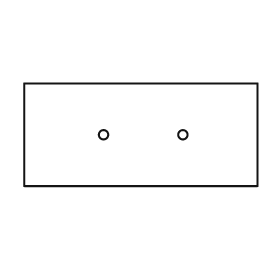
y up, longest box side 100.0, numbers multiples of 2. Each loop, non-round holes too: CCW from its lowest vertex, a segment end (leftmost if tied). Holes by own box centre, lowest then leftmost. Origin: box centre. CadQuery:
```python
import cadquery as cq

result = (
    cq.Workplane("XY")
    .moveTo(-50.0, -22.0)
    .lineTo(50.0, -22.0)
    .lineTo(50.0, 22.0)
    .lineTo(-50.0, 22.0)
    .close()
    .moveTo(-16.0, 0.0)
    .circle(2.0)
    .moveTo(18.0, 0.0)
    .circle(2.0)
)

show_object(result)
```